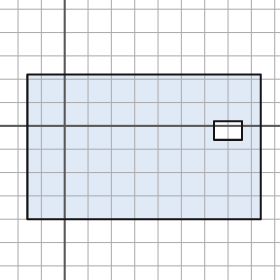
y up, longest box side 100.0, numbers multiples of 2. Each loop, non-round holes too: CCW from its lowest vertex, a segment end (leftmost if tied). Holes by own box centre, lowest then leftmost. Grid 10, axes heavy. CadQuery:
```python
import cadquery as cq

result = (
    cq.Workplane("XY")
    .moveTo(-16.0, -40.0)
    .lineTo(84.0, -40.0)
    .lineTo(84.0, 22.0)
    .lineTo(-16.0, 22.0)
    .close()
    .moveTo(64.0, -6.0)
    .lineTo(76.0, -6.0)
    .lineTo(76.0, 2.0)
    .lineTo(64.0, 2.0)
    .close()
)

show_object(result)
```